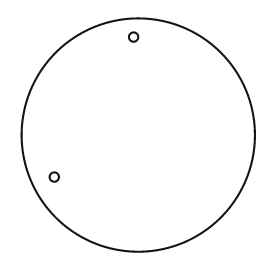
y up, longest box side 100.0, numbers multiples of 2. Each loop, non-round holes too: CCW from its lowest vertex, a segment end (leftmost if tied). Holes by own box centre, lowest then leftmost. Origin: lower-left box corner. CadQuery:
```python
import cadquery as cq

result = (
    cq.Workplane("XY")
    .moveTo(50.0, 50.0)
    .circle(50.0)
    .moveTo(14.0, 32.0)
    .circle(2.0)
    .moveTo(48.0, 92.0)
    .circle(2.0)
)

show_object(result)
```